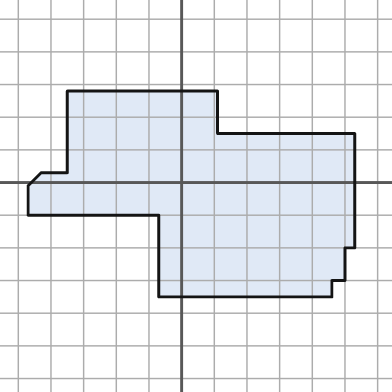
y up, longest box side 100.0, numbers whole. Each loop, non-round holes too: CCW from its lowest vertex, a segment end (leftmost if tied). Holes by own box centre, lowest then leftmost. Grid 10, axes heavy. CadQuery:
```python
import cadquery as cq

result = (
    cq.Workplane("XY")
    .moveTo(-7.0, -35.0)
    .lineTo(46.0, -35.0)
    .lineTo(46.0, -30.0)
    .lineTo(50.0, -30.0)
    .lineTo(50.0, -20.0)
    .lineTo(53.0, -20.0)
    .lineTo(53.0, 15.0)
    .lineTo(11.0, 15.0)
    .lineTo(11.0, 28.0)
    .lineTo(-35.0, 28.0)
    .lineTo(-35.0, 3.0)
    .lineTo(-43.0, 3.0)
    .lineTo(-47.0, -1.0)
    .lineTo(-47.0, -10.0)
    .lineTo(-7.0, -10.0)
    .close()
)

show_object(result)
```